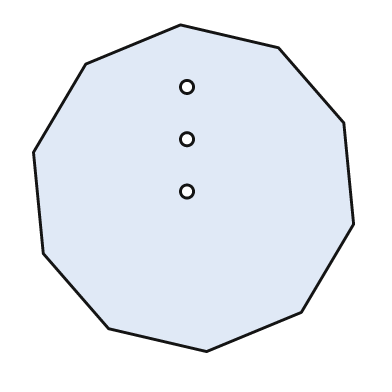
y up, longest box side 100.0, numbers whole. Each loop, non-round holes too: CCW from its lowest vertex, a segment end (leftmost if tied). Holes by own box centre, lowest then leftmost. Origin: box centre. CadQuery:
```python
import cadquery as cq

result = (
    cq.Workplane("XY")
    .moveTo(4.0, -50.0)
    .lineTo(33.0, -38.0)
    .lineTo(49.0, -11.0)
    .lineTo(46.0, 20.0)
    .lineTo(26.0, 43.0)
    .lineTo(-4.0, 50.0)
    .lineTo(-33.0, 38.0)
    .lineTo(-49.0, 11.0)
    .lineTo(-46.0, -20.0)
    .lineTo(-26.0, -43.0)
    .close()
    .moveTo(-2.0, -1.0)
    .circle(2.0)
    .moveTo(-2.0, 15.0)
    .circle(2.0)
    .moveTo(-2.0, 31.0)
    .circle(2.0)
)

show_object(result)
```